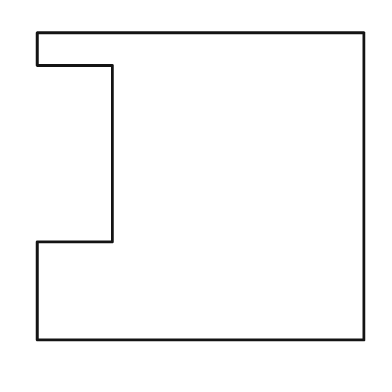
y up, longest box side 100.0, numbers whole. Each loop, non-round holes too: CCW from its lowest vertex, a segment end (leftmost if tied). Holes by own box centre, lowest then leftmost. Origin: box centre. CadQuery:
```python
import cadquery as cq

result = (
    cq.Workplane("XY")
    .moveTo(-50.0, -47.0)
    .lineTo(50.0, -47.0)
    .lineTo(50.0, 47.0)
    .lineTo(-50.0, 47.0)
    .lineTo(-50.0, 37.0)
    .lineTo(-27.0, 37.0)
    .lineTo(-27.0, -17.0)
    .lineTo(-50.0, -17.0)
    .close()
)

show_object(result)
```